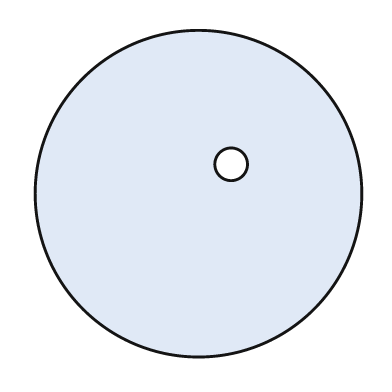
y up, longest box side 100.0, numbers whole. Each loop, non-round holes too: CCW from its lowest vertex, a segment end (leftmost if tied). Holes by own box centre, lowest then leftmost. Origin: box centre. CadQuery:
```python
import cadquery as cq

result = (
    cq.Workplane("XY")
    .moveTo(0.0, 0.0)
    .circle(50.0)
    .moveTo(10.0, 9.0)
    .circle(5.0)
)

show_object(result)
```